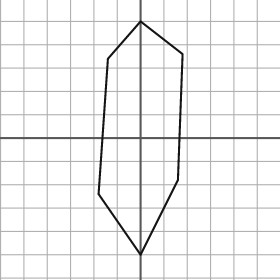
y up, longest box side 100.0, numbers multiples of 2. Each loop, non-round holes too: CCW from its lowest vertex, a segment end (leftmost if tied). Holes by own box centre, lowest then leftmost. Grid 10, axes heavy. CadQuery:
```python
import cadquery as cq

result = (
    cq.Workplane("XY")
    .moveTo(0.0, -50.0)
    .lineTo(16.0, -18.0)
    .lineTo(18.0, 36.0)
    .lineTo(0.0, 50.0)
    .lineTo(-14.0, 34.0)
    .lineTo(-18.0, -24.0)
    .close()
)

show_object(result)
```